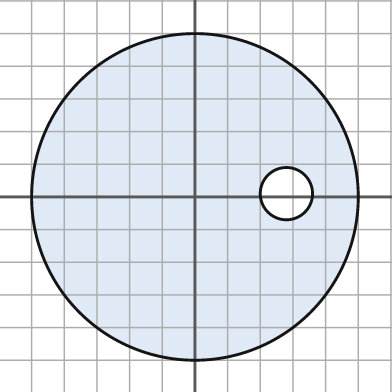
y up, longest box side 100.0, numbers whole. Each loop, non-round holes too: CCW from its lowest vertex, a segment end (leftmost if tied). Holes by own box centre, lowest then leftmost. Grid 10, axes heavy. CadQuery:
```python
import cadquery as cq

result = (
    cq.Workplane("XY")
    .moveTo(0.0, 0.0)
    .circle(50.0)
    .moveTo(28.0, 1.0)
    .circle(8.0)
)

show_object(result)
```